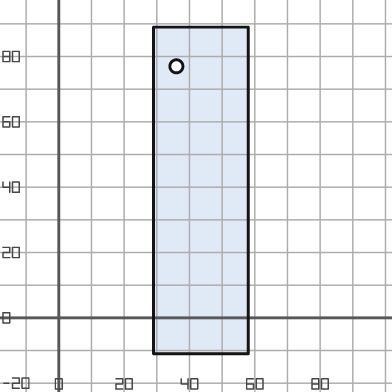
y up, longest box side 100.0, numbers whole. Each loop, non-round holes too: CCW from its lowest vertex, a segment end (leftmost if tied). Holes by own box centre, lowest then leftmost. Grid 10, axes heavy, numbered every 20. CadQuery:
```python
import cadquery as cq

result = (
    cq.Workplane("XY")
    .moveTo(29.0, -11.0)
    .lineTo(58.0, -11.0)
    .lineTo(58.0, 89.0)
    .lineTo(29.0, 89.0)
    .close()
    .moveTo(36.0, 77.0)
    .circle(2.0)
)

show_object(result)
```